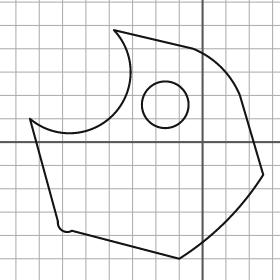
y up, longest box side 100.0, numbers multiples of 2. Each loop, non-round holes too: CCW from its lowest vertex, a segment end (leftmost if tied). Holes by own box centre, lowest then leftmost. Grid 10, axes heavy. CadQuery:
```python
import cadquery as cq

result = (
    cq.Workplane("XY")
    .moveTo(-10.0, -50.0)
    .threePointArc((10.0, -34.0), (26.0, -14.0))
    .lineTo(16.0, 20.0)
    .threePointArc((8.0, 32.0), (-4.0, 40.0))
    .lineTo(-38.0, 48.0)
    .threePointArc((-38.0, 12.0), (-74.0, 10.0))
    .lineTo(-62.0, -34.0)
    .threePointArc((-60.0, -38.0), (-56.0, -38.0))
    .close()
    .moveTo(-16.0, 16.0)
    .circle(10.0)
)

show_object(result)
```